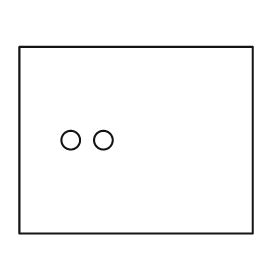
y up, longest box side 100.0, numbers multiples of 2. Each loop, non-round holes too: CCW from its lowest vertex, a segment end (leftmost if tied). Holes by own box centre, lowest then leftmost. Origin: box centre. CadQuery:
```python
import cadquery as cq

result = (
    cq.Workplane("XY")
    .moveTo(-50.0, -40.0)
    .lineTo(50.0, -40.0)
    .lineTo(50.0, 40.0)
    .lineTo(-50.0, 40.0)
    .close()
    .moveTo(-28.0, 0.0)
    .circle(4.0)
    .moveTo(-14.0, 0.0)
    .circle(4.0)
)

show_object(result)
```